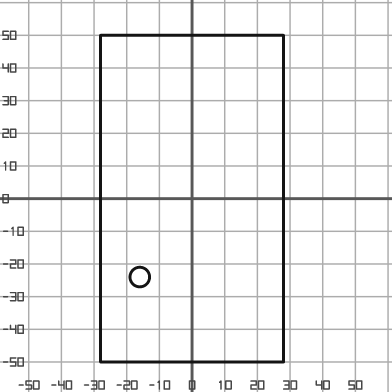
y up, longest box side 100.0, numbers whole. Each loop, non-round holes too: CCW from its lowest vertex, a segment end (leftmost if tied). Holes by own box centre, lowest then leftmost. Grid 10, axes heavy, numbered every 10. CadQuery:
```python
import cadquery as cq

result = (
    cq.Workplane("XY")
    .moveTo(-28.0, -50.0)
    .lineTo(28.0, -50.0)
    .lineTo(28.0, 50.0)
    .lineTo(-28.0, 50.0)
    .close()
    .moveTo(-16.0, -24.0)
    .circle(3.0)
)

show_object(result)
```